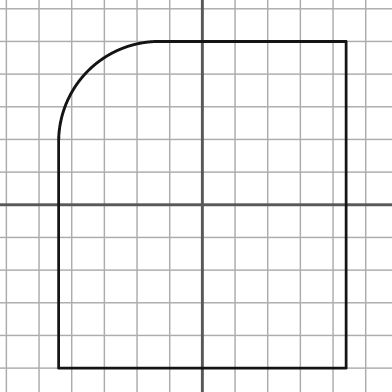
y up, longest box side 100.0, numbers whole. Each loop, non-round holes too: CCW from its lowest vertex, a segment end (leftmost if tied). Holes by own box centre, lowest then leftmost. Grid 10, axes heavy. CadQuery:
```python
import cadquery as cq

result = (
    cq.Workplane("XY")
    .moveTo(-44.0, -50.0)
    .lineTo(44.0, -50.0)
    .lineTo(44.0, 50.0)
    .lineTo(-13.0, 50.0)
    .threePointArc((-35.0, 41.0), (-44.0, 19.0))
    .close()
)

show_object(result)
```